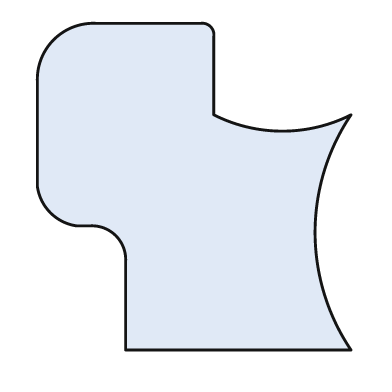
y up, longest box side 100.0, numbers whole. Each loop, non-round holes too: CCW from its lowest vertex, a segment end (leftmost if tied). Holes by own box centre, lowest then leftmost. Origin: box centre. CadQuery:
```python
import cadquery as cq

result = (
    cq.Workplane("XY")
    .moveTo(-21.0, -50.0)
    .lineTo(48.0, -50.0)
    .threePointArc((37.0, -14.0), (48.0, 22.0))
    .threePointArc((27.0, 17.0), (6.0, 22.0))
    .lineTo(6.0, 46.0)
    .threePointArc((5.0, 49.0), (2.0, 50.0))
    .lineTo(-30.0, 50.0)
    .threePointArc((-43.0, 45.0), (-48.0, 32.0))
    .lineTo(-48.0, 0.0)
    .threePointArc((-44.0, -8.0), (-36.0, -12.0))
    .lineTo(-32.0, -12.0)
    .threePointArc((-24.0, -15.0), (-21.0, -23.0))
    .close()
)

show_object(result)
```